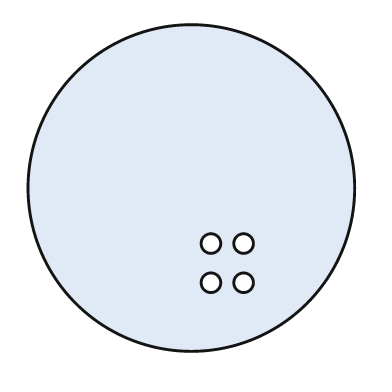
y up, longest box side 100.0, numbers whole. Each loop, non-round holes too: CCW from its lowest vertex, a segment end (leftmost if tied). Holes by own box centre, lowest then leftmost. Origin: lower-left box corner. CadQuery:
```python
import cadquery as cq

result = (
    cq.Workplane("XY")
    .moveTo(50.0, 50.0)
    .circle(50.0)
    .moveTo(56.0, 21.0)
    .circle(3.0)
    .moveTo(66.0, 21.0)
    .circle(3.0)
    .moveTo(56.0, 33.0)
    .circle(3.0)
    .moveTo(66.0, 33.0)
    .circle(3.0)
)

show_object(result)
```